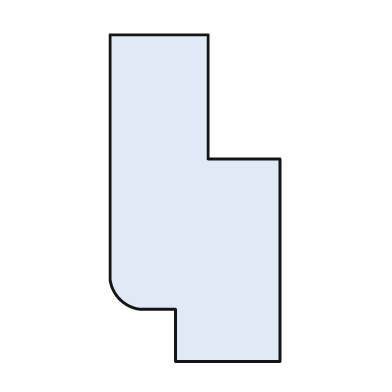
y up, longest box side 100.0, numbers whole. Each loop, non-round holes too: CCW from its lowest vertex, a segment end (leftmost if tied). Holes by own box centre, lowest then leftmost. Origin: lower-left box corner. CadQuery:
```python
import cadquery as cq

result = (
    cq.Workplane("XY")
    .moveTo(20.0, 0.0)
    .lineTo(52.0, 0.0)
    .lineTo(52.0, 62.0)
    .lineTo(30.0, 62.0)
    .lineTo(30.0, 100.0)
    .lineTo(0.0, 100.0)
    .lineTo(0.0, 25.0)
    .threePointArc((3.0, 19.0), (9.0, 16.0))
    .lineTo(20.0, 16.0)
    .close()
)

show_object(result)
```